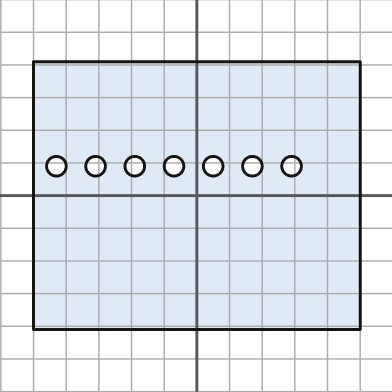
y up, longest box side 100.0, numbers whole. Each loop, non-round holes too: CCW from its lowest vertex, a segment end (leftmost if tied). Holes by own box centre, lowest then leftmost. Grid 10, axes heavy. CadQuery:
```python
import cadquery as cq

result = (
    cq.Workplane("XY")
    .moveTo(-50.0, -41.0)
    .lineTo(50.0, -41.0)
    .lineTo(50.0, 41.0)
    .lineTo(-50.0, 41.0)
    .close()
    .moveTo(-43.0, 9.0)
    .circle(3.0)
    .moveTo(-31.0, 9.0)
    .circle(3.0)
    .moveTo(-19.0, 9.0)
    .circle(3.0)
    .moveTo(-7.0, 9.0)
    .circle(3.0)
    .moveTo(5.0, 9.0)
    .circle(3.0)
    .moveTo(17.0, 9.0)
    .circle(3.0)
    .moveTo(29.0, 9.0)
    .circle(3.0)
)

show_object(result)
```